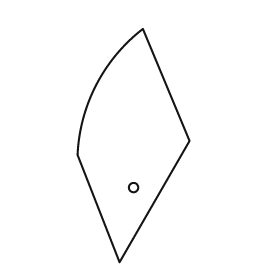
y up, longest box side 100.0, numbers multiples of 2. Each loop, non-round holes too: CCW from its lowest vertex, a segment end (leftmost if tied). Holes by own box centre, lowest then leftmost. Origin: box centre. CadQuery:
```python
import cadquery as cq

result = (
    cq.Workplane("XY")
    .moveTo(-6.0, -50.0)
    .lineTo(24.0, 2.0)
    .lineTo(4.0, 50.0)
    .threePointArc((-16.0, 26.0), (-24.0, -4.0))
    .close()
    .moveTo(0.0, -18.0)
    .circle(2.0)
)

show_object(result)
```